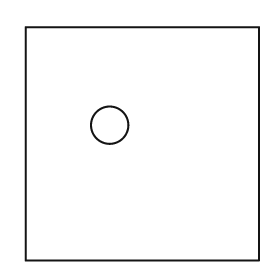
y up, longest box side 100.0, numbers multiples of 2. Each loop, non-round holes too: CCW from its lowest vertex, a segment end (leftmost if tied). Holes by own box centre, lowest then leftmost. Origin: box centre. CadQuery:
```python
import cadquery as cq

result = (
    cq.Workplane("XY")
    .moveTo(-50.0, -50.0)
    .lineTo(50.0, -50.0)
    .lineTo(50.0, 50.0)
    .lineTo(-50.0, 50.0)
    .close()
    .moveTo(-14.0, 8.0)
    .circle(8.0)
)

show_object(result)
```